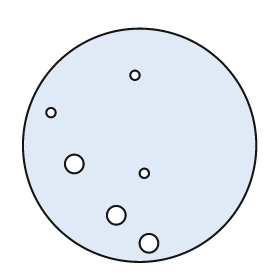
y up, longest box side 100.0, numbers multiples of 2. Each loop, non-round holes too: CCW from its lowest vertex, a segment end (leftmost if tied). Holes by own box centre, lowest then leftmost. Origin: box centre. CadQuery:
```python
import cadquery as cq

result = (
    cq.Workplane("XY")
    .moveTo(0.0, 0.0)
    .circle(50.0)
    .moveTo(4.0, -42.0)
    .circle(4.0)
    .moveTo(-10.0, -30.0)
    .circle(4.0)
    .moveTo(2.0, -12.0)
    .circle(2.0)
    .moveTo(-28.0, -8.0)
    .circle(4.0)
    .moveTo(-38.0, 14.0)
    .circle(2.0)
    .moveTo(-2.0, 30.0)
    .circle(2.0)
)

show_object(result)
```